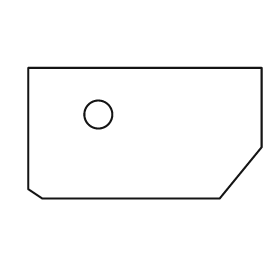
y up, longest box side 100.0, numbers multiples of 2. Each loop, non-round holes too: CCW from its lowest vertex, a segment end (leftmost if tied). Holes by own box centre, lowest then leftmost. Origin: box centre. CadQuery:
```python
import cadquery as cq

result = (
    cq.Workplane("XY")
    .moveTo(-44.0, -28.0)
    .lineTo(32.0, -28.0)
    .lineTo(50.0, -6.0)
    .lineTo(50.0, 28.0)
    .lineTo(-50.0, 28.0)
    .lineTo(-50.0, -24.0)
    .close()
    .moveTo(-20.0, 8.0)
    .circle(6.0)
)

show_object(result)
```